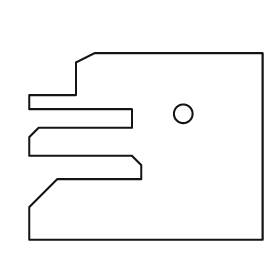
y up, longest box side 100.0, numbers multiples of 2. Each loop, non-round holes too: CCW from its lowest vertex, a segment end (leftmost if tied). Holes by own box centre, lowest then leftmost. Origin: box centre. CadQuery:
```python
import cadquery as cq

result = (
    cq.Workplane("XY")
    .moveTo(-50.0, -40.0)
    .lineTo(50.0, -40.0)
    .lineTo(50.0, 40.0)
    .lineTo(-22.0, 40.0)
    .lineTo(-30.0, 36.0)
    .lineTo(-30.0, 22.0)
    .lineTo(-50.0, 22.0)
    .lineTo(-50.0, 16.0)
    .lineTo(-6.0, 16.0)
    .lineTo(-6.0, 8.0)
    .lineTo(-46.0, 8.0)
    .lineTo(-50.0, 4.0)
    .lineTo(-50.0, -4.0)
    .lineTo(-6.0, -4.0)
    .lineTo(-2.0, -8.0)
    .lineTo(-2.0, -14.0)
    .lineTo(-38.0, -14.0)
    .lineTo(-50.0, -26.0)
    .close()
    .moveTo(16.0, 14.0)
    .circle(4.0)
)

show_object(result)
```